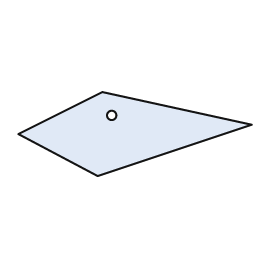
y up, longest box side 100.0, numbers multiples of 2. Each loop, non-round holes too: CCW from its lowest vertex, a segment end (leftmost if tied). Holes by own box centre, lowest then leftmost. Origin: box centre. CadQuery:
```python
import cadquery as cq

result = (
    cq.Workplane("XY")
    .moveTo(-16.0, -18.0)
    .lineTo(50.0, 4.0)
    .lineTo(-14.0, 18.0)
    .lineTo(-50.0, 0.0)
    .close()
    .moveTo(-10.0, 8.0)
    .circle(2.0)
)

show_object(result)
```